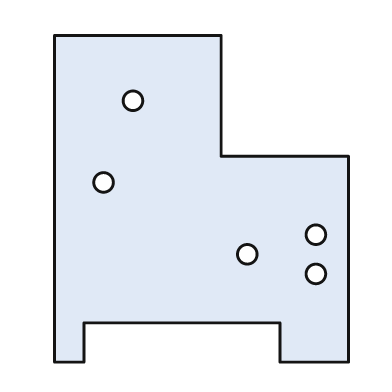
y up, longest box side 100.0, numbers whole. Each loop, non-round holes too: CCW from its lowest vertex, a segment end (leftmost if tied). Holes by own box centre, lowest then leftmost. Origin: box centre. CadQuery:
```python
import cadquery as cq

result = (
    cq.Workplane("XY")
    .moveTo(-45.0, -50.0)
    .lineTo(-36.0, -50.0)
    .lineTo(-36.0, -38.0)
    .lineTo(24.0, -38.0)
    .lineTo(24.0, -50.0)
    .lineTo(45.0, -50.0)
    .lineTo(45.0, 13.0)
    .lineTo(6.0, 13.0)
    .lineTo(6.0, 50.0)
    .lineTo(-45.0, 50.0)
    .close()
    .moveTo(35.0, -23.0)
    .circle(3.0)
    .moveTo(14.0, -17.0)
    .circle(3.0)
    .moveTo(35.0, -11.0)
    .circle(3.0)
    .moveTo(-30.0, 5.0)
    .circle(3.0)
    .moveTo(-21.0, 30.0)
    .circle(3.0)
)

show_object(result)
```